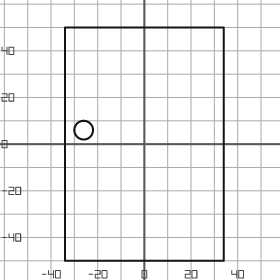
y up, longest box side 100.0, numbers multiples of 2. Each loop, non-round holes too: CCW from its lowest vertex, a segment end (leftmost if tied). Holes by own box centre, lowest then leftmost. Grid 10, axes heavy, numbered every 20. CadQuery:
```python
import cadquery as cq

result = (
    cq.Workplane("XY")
    .moveTo(-34.0, -50.0)
    .lineTo(34.0, -50.0)
    .lineTo(34.0, 50.0)
    .lineTo(-34.0, 50.0)
    .close()
    .moveTo(-26.0, 6.0)
    .circle(4.0)
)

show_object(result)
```